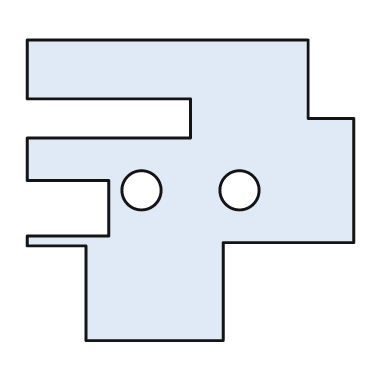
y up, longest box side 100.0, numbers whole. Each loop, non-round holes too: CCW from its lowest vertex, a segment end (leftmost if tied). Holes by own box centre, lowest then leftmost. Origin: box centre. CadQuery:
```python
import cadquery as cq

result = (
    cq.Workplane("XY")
    .moveTo(-32.0, -46.0)
    .lineTo(10.0, -46.0)
    .lineTo(10.0, -16.0)
    .lineTo(50.0, -16.0)
    .lineTo(50.0, 22.0)
    .lineTo(36.0, 22.0)
    .lineTo(36.0, 46.0)
    .lineTo(-50.0, 46.0)
    .lineTo(-50.0, 28.0)
    .lineTo(0.0, 28.0)
    .lineTo(0.0, 16.0)
    .lineTo(-50.0, 16.0)
    .lineTo(-50.0, 3.0)
    .lineTo(-25.0, 3.0)
    .lineTo(-25.0, -14.0)
    .lineTo(-50.0, -14.0)
    .lineTo(-50.0, -17.0)
    .lineTo(-32.0, -17.0)
    .close()
    .moveTo(-15.0, 0.0)
    .circle(6.0)
    .moveTo(15.0, 0.0)
    .circle(6.0)
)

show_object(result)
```